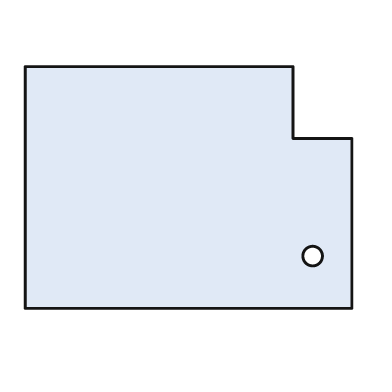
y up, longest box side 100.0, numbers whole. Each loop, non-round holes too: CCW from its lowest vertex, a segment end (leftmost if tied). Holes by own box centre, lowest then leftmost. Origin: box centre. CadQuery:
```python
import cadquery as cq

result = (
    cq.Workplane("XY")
    .moveTo(-50.0, -37.0)
    .lineTo(50.0, -37.0)
    .lineTo(50.0, 15.0)
    .lineTo(32.0, 15.0)
    .lineTo(32.0, 37.0)
    .lineTo(-50.0, 37.0)
    .close()
    .moveTo(38.0, -21.0)
    .circle(3.0)
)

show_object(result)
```